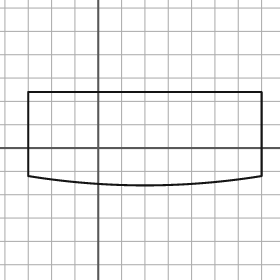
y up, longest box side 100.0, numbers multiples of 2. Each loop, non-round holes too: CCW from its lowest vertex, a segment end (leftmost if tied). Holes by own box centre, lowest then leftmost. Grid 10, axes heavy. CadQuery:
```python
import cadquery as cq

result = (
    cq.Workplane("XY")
    .moveTo(-30.0, -12.0)
    .threePointArc((20.0, -16.0), (70.0, -12.0))
    .lineTo(70.0, 24.0)
    .lineTo(-30.0, 24.0)
    .close()
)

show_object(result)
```